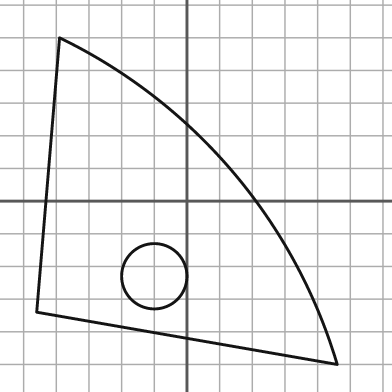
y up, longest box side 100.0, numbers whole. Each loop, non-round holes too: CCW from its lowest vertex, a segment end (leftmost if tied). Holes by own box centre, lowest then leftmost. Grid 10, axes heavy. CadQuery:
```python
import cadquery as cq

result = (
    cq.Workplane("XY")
    .moveTo(46.0, -50.0)
    .threePointArc((14.0, 9.0), (-39.0, 50.0))
    .lineTo(-46.0, -34.0)
    .close()
    .moveTo(-10.0, -23.0)
    .circle(10.0)
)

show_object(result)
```